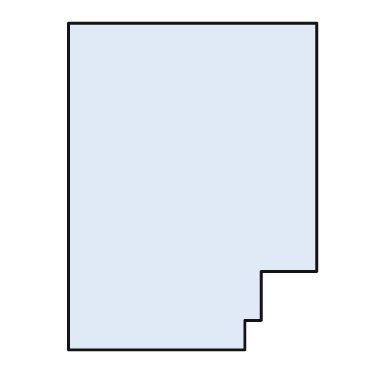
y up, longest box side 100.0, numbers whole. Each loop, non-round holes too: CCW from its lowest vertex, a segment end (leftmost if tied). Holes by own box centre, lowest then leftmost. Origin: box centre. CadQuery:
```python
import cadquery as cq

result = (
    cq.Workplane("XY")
    .moveTo(-38.0, -50.0)
    .lineTo(16.0, -50.0)
    .lineTo(16.0, -41.0)
    .lineTo(21.0, -41.0)
    .lineTo(21.0, -26.0)
    .lineTo(38.0, -26.0)
    .lineTo(38.0, 50.0)
    .lineTo(-38.0, 50.0)
    .close()
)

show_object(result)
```